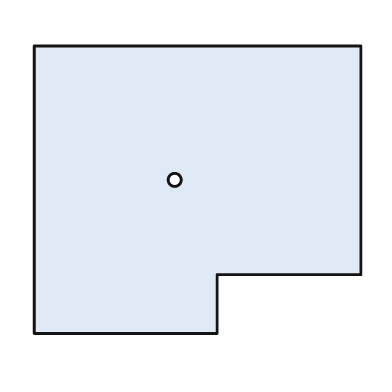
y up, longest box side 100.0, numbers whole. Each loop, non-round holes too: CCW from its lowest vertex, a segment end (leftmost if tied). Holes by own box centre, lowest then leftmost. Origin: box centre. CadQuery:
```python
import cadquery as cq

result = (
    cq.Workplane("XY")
    .moveTo(-50.0, -44.0)
    .lineTo(6.0, -44.0)
    .lineTo(6.0, -26.0)
    .lineTo(50.0, -26.0)
    .lineTo(50.0, 44.0)
    .lineTo(-50.0, 44.0)
    .close()
    .moveTo(-7.0, 3.0)
    .circle(2.0)
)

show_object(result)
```